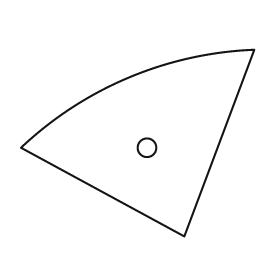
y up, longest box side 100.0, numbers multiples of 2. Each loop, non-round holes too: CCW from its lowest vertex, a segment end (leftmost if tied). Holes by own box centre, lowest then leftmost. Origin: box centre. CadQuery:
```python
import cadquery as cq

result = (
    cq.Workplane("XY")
    .moveTo(20.0, -40.0)
    .lineTo(50.0, 40.0)
    .threePointArc((-4.0, 28.0), (-50.0, -2.0))
    .close()
    .moveTo(4.0, -2.0)
    .circle(4.0)
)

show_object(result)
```